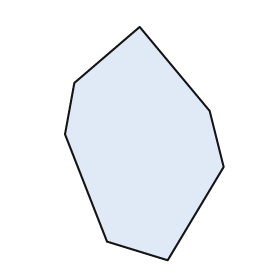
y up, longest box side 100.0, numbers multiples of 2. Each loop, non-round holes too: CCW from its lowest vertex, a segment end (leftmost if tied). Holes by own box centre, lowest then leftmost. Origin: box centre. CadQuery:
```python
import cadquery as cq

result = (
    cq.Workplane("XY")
    .moveTo(10.0, -50.0)
    .lineTo(34.0, -10.0)
    .lineTo(28.0, 14.0)
    .lineTo(-2.0, 50.0)
    .lineTo(-30.0, 26.0)
    .lineTo(-34.0, 4.0)
    .lineTo(-16.0, -42.0)
    .close()
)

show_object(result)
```